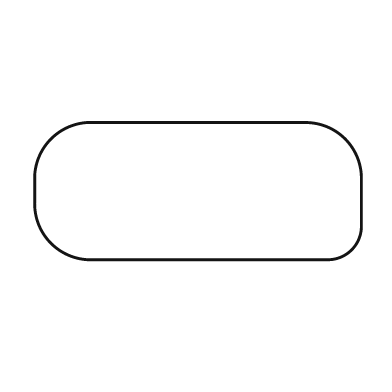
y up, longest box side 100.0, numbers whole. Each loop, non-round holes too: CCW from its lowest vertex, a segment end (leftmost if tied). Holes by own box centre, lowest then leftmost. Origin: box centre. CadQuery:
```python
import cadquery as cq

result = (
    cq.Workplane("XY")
    .moveTo(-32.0, -21.0)
    .lineTo(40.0, -21.0)
    .threePointArc((47.0, -18.0), (50.0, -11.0))
    .lineTo(50.0, 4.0)
    .threePointArc((45.0, 16.0), (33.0, 21.0))
    .lineTo(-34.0, 21.0)
    .threePointArc((-45.0, 16.0), (-50.0, 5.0))
    .lineTo(-50.0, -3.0)
    .threePointArc((-45.0, -16.0), (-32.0, -21.0))
    .close()
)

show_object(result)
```